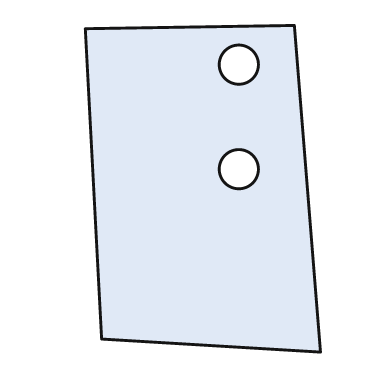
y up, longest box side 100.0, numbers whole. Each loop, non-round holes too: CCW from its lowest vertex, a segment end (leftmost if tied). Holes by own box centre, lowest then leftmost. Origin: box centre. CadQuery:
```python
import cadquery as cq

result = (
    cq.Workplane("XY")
    .moveTo(36.0, -50.0)
    .lineTo(28.0, 50.0)
    .lineTo(-36.0, 49.0)
    .lineTo(-31.0, -46.0)
    .close()
    .moveTo(11.0, 6.0)
    .circle(6.0)
    .moveTo(11.0, 38.0)
    .circle(6.0)
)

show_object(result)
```